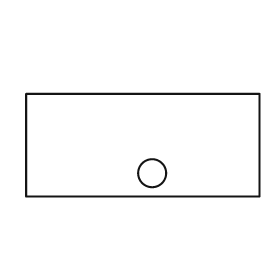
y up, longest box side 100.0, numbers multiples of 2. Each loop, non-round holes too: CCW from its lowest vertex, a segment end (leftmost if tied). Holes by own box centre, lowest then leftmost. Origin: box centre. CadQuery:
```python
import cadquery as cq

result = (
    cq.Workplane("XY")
    .moveTo(-50.0, -22.0)
    .lineTo(50.0, -22.0)
    .lineTo(50.0, 22.0)
    .lineTo(-50.0, 22.0)
    .close()
    .moveTo(4.0, -12.0)
    .circle(6.0)
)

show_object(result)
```